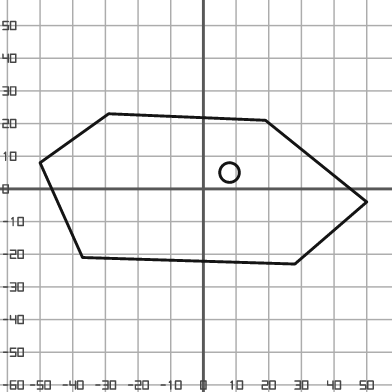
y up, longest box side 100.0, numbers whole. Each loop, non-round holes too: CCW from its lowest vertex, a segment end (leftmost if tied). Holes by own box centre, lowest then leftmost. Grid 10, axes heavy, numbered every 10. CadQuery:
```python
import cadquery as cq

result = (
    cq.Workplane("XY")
    .moveTo(28.0, -23.0)
    .lineTo(50.0, -4.0)
    .lineTo(19.0, 21.0)
    .lineTo(-29.0, 23.0)
    .lineTo(-50.0, 8.0)
    .lineTo(-37.0, -21.0)
    .close()
    .moveTo(8.0, 5.0)
    .circle(3.0)
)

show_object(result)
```